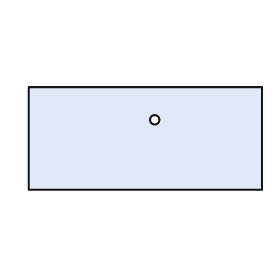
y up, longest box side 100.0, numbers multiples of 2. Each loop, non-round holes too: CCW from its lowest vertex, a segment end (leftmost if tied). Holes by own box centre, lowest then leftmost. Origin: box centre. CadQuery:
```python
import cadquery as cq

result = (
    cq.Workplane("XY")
    .moveTo(-50.0, -22.0)
    .lineTo(50.0, -22.0)
    .lineTo(50.0, 22.0)
    .lineTo(-50.0, 22.0)
    .close()
    .moveTo(4.0, 8.0)
    .circle(2.0)
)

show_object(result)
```